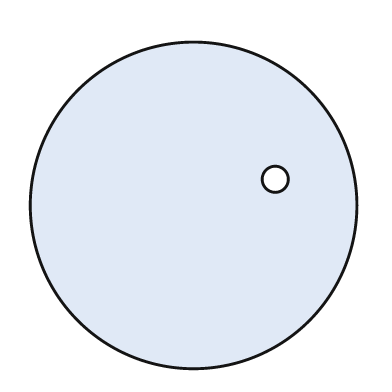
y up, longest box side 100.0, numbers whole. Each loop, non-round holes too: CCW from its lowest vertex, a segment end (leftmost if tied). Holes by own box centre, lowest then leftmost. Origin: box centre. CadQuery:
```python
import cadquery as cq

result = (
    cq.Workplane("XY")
    .moveTo(0.0, 0.0)
    .circle(50.0)
    .moveTo(25.0, 8.0)
    .circle(4.0)
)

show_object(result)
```